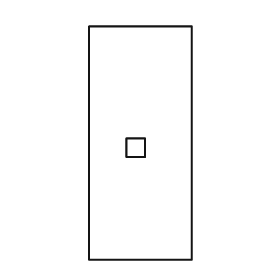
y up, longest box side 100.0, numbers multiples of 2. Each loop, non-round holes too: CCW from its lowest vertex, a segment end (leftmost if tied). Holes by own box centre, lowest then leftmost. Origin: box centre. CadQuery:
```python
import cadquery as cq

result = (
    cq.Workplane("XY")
    .moveTo(-22.0, -50.0)
    .lineTo(22.0, -50.0)
    .lineTo(22.0, 50.0)
    .lineTo(-22.0, 50.0)
    .close()
    .moveTo(-6.0, -6.0)
    .lineTo(2.0, -6.0)
    .lineTo(2.0, 2.0)
    .lineTo(-6.0, 2.0)
    .close()
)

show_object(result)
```